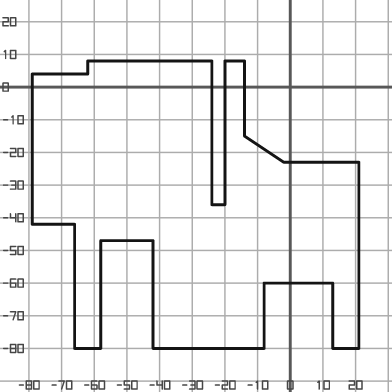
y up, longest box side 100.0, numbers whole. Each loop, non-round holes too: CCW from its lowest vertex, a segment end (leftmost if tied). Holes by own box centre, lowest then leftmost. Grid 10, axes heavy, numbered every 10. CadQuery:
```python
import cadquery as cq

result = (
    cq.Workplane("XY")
    .moveTo(-66.0, -80.0)
    .lineTo(-58.0, -80.0)
    .lineTo(-58.0, -47.0)
    .lineTo(-42.0, -47.0)
    .lineTo(-42.0, -80.0)
    .lineTo(-8.0, -80.0)
    .lineTo(-8.0, -60.0)
    .lineTo(13.0, -60.0)
    .lineTo(13.0, -80.0)
    .lineTo(21.0, -80.0)
    .lineTo(21.0, -23.0)
    .lineTo(-2.0, -23.0)
    .lineTo(-14.0, -15.0)
    .lineTo(-14.0, 8.0)
    .lineTo(-20.0, 8.0)
    .lineTo(-20.0, -36.0)
    .lineTo(-24.0, -36.0)
    .lineTo(-24.0, 8.0)
    .lineTo(-62.0, 8.0)
    .lineTo(-62.0, 4.0)
    .lineTo(-79.0, 4.0)
    .lineTo(-79.0, -42.0)
    .lineTo(-66.0, -42.0)
    .close()
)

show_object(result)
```